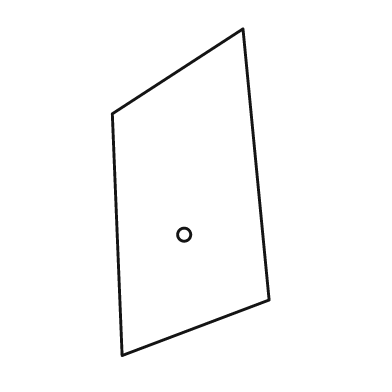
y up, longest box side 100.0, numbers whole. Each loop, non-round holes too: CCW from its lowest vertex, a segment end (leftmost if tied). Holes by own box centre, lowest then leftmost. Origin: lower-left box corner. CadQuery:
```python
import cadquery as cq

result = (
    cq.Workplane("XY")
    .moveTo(3.0, 0.0)
    .lineTo(48.0, 17.0)
    .lineTo(40.0, 100.0)
    .lineTo(0.0, 74.0)
    .close()
    .moveTo(22.0, 37.0)
    .circle(2.0)
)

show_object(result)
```